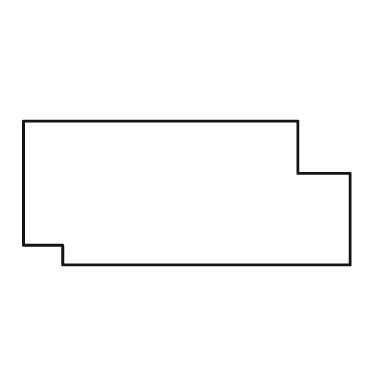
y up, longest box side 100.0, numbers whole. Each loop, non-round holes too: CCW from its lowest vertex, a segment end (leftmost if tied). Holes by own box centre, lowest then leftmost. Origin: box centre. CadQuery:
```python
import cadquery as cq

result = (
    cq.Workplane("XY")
    .moveTo(-38.0, -22.0)
    .lineTo(50.0, -22.0)
    .lineTo(50.0, 6.0)
    .lineTo(34.0, 6.0)
    .lineTo(34.0, 22.0)
    .lineTo(-50.0, 22.0)
    .lineTo(-50.0, -16.0)
    .lineTo(-38.0, -16.0)
    .close()
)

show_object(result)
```